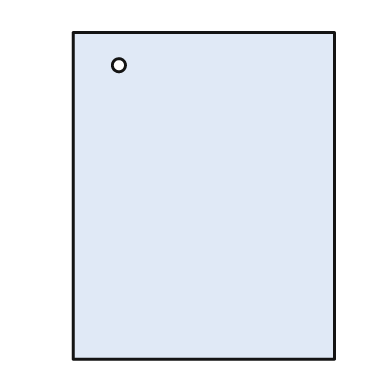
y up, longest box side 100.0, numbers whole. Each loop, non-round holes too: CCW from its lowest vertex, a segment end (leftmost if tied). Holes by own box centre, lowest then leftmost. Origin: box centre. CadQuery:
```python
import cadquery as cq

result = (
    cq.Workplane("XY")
    .moveTo(-40.0, -50.0)
    .lineTo(40.0, -50.0)
    .lineTo(40.0, 50.0)
    .lineTo(-40.0, 50.0)
    .close()
    .moveTo(-26.0, 40.0)
    .circle(2.0)
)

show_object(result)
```